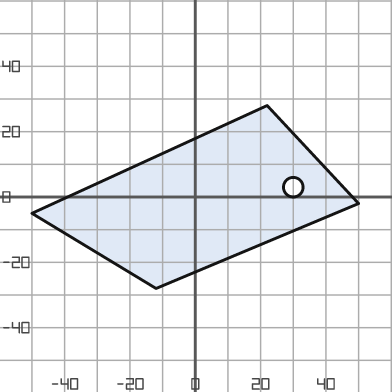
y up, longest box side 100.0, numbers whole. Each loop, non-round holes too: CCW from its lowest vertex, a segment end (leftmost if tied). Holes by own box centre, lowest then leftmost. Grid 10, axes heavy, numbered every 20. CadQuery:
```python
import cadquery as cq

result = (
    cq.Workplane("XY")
    .moveTo(-12.0, -28.0)
    .lineTo(50.0, -2.0)
    .lineTo(22.0, 28.0)
    .lineTo(-50.0, -5.0)
    .close()
    .moveTo(30.0, 3.0)
    .circle(3.0)
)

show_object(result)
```